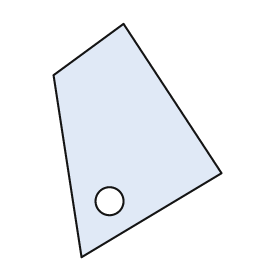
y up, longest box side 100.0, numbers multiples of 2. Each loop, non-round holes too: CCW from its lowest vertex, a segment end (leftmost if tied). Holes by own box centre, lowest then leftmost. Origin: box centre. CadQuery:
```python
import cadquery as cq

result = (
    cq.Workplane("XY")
    .moveTo(-24.0, -50.0)
    .lineTo(36.0, -14.0)
    .lineTo(-6.0, 50.0)
    .lineTo(-36.0, 28.0)
    .close()
    .moveTo(-12.0, -26.0)
    .circle(6.0)
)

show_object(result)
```